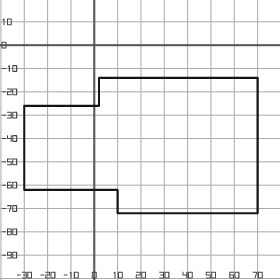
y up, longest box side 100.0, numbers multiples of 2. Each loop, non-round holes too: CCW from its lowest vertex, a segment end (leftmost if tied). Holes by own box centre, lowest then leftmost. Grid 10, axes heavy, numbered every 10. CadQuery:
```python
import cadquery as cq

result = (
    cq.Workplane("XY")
    .moveTo(10.0, -72.0)
    .lineTo(70.0, -72.0)
    .lineTo(70.0, -14.0)
    .lineTo(2.0, -14.0)
    .lineTo(2.0, -26.0)
    .lineTo(-30.0, -26.0)
    .lineTo(-30.0, -62.0)
    .lineTo(10.0, -62.0)
    .close()
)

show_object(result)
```